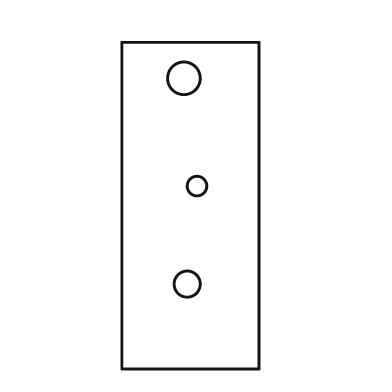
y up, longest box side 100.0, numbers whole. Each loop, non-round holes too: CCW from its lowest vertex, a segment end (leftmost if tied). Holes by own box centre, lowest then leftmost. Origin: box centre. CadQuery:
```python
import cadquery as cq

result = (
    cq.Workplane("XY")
    .moveTo(-21.0, -50.0)
    .lineTo(21.0, -50.0)
    .lineTo(21.0, 50.0)
    .lineTo(-21.0, 50.0)
    .close()
    .moveTo(-1.0, -24.0)
    .circle(4.0)
    .moveTo(2.0, 6.0)
    .circle(3.0)
    .moveTo(-2.0, 39.0)
    .circle(5.0)
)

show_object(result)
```